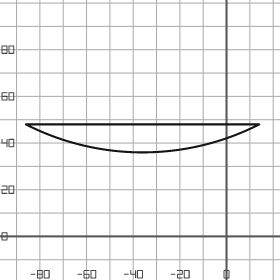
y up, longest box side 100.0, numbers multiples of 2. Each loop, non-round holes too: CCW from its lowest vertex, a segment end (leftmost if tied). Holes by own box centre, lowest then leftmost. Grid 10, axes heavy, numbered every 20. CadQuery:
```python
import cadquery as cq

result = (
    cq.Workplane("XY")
    .moveTo(-86.0, 48.0)
    .threePointArc((-36.0, 36.0), (14.0, 48.0))
    .close()
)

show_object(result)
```